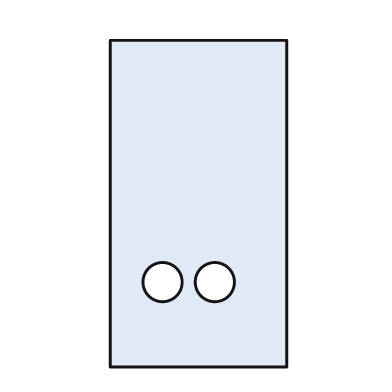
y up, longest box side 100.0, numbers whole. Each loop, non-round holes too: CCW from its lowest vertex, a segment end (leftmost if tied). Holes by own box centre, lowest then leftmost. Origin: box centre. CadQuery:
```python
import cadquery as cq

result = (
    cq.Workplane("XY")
    .moveTo(-27.0, -50.0)
    .lineTo(27.0, -50.0)
    .lineTo(27.0, 50.0)
    .lineTo(-27.0, 50.0)
    .close()
    .moveTo(-11.0, -24.0)
    .circle(6.0)
    .moveTo(5.0, -24.0)
    .circle(6.0)
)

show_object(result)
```